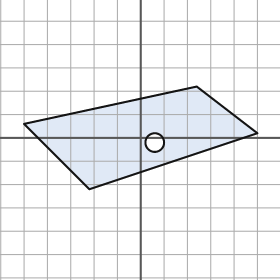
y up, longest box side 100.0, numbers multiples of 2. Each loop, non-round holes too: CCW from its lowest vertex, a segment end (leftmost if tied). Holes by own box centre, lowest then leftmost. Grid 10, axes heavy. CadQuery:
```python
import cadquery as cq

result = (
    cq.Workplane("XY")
    .moveTo(-22.0, -22.0)
    .lineTo(50.0, 2.0)
    .lineTo(24.0, 22.0)
    .lineTo(-50.0, 6.0)
    .close()
    .moveTo(6.0, -2.0)
    .circle(4.0)
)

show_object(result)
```